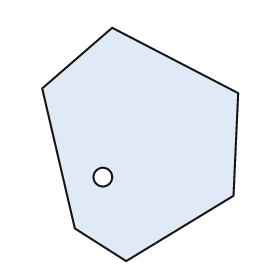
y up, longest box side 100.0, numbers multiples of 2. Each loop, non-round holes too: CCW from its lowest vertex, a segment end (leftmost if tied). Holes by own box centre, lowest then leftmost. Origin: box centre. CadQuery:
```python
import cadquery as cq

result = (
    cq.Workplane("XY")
    .moveTo(-6.0, -50.0)
    .lineTo(40.0, -22.0)
    .lineTo(42.0, 22.0)
    .lineTo(-12.0, 50.0)
    .lineTo(-42.0, 24.0)
    .lineTo(-28.0, -36.0)
    .close()
    .moveTo(-16.0, -14.0)
    .circle(4.0)
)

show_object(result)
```